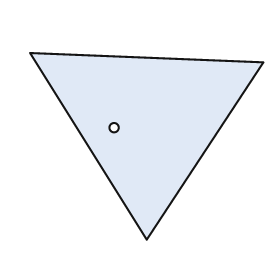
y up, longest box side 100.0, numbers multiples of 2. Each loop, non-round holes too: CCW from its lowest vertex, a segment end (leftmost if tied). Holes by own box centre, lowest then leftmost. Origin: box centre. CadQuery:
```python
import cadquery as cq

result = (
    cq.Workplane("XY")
    .moveTo(0.0, -40.0)
    .lineTo(50.0, 36.0)
    .lineTo(-50.0, 40.0)
    .close()
    .moveTo(-14.0, 8.0)
    .circle(2.0)
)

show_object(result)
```